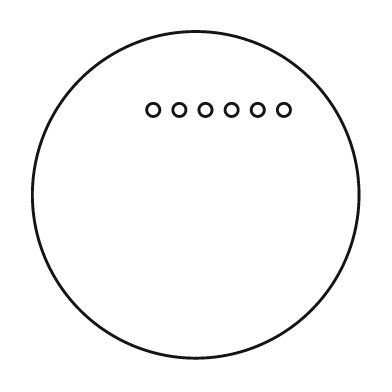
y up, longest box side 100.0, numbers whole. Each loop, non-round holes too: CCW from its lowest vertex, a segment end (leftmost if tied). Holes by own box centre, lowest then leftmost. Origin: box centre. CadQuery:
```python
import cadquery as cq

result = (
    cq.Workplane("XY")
    .moveTo(0.0, 0.0)
    .circle(50.0)
    .moveTo(-13.0, 26.0)
    .circle(2.0)
    .moveTo(-5.0, 26.0)
    .circle(2.0)
    .moveTo(3.0, 26.0)
    .circle(2.0)
    .moveTo(11.0, 26.0)
    .circle(2.0)
    .moveTo(19.0, 26.0)
    .circle(2.0)
    .moveTo(27.0, 26.0)
    .circle(2.0)
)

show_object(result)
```